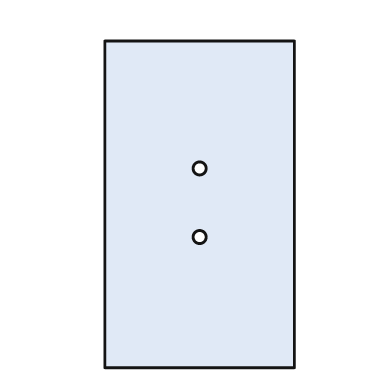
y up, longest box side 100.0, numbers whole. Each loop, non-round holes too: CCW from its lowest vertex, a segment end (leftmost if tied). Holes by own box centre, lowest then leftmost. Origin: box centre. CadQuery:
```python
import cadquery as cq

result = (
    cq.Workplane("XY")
    .moveTo(-29.0, -50.0)
    .lineTo(29.0, -50.0)
    .lineTo(29.0, 50.0)
    .lineTo(-29.0, 50.0)
    .close()
    .moveTo(0.0, -10.0)
    .circle(2.0)
    .moveTo(0.0, 11.0)
    .circle(2.0)
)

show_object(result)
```